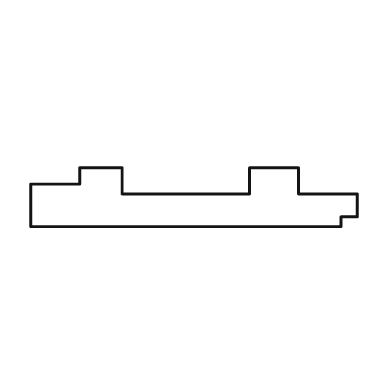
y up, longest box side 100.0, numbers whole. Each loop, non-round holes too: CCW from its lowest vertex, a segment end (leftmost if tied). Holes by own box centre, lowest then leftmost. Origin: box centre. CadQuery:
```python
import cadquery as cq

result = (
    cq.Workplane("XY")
    .moveTo(-50.0, -9.0)
    .lineTo(45.0, -9.0)
    .lineTo(45.0, -6.0)
    .lineTo(50.0, -6.0)
    .lineTo(50.0, 1.0)
    .lineTo(32.0, 1.0)
    .lineTo(32.0, 9.0)
    .lineTo(17.0, 9.0)
    .lineTo(17.0, 1.0)
    .lineTo(-22.0, 1.0)
    .lineTo(-22.0, 9.0)
    .lineTo(-35.0, 9.0)
    .lineTo(-35.0, 4.0)
    .lineTo(-50.0, 4.0)
    .close()
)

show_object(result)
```